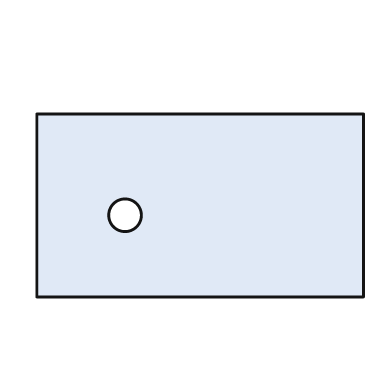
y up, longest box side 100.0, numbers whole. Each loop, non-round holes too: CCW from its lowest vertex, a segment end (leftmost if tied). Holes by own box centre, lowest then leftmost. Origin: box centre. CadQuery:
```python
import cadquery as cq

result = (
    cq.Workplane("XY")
    .moveTo(-50.0, -28.0)
    .lineTo(50.0, -28.0)
    .lineTo(50.0, 28.0)
    .lineTo(-50.0, 28.0)
    .close()
    .moveTo(-23.0, -3.0)
    .circle(5.0)
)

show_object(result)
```